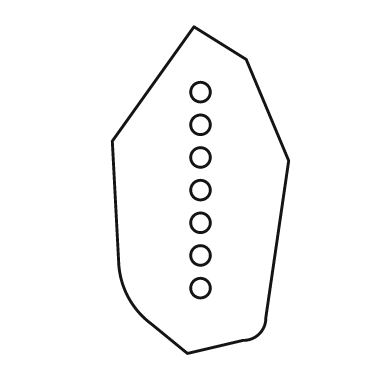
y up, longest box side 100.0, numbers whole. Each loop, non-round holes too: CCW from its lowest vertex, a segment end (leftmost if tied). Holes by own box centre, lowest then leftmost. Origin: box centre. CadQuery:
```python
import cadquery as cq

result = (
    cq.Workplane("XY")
    .moveTo(-4.0, -50.0)
    .lineTo(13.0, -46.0)
    .threePointArc((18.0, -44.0), (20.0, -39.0))
    .lineTo(27.0, 9.0)
    .lineTo(14.0, 40.0)
    .lineTo(-2.0, 50.0)
    .lineTo(-27.0, 15.0)
    .lineTo(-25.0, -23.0)
    .threePointArc((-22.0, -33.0), (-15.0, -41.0))
    .close()
    .moveTo(0.0, -30.0)
    .circle(3.0)
    .moveTo(0.0, -20.0)
    .circle(3.0)
    .moveTo(0.0, -10.0)
    .circle(3.0)
    .moveTo(0.0, 0.0)
    .circle(3.0)
    .moveTo(0.0, 10.0)
    .circle(3.0)
    .moveTo(0.0, 20.0)
    .circle(3.0)
    .moveTo(0.0, 30.0)
    .circle(3.0)
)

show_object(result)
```